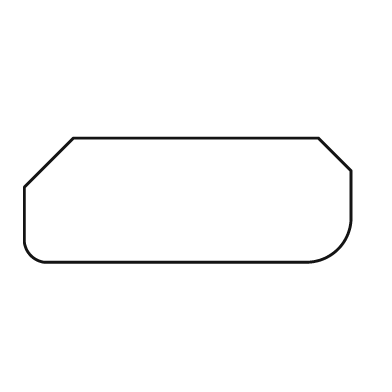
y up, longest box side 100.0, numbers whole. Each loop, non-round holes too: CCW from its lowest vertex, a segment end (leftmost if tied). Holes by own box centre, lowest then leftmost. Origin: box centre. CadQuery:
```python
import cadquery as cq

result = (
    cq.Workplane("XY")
    .moveTo(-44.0, -19.0)
    .lineTo(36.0, -19.0)
    .threePointArc((46.0, -15.0), (50.0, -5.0))
    .lineTo(50.0, 9.0)
    .lineTo(40.0, 19.0)
    .lineTo(-35.0, 19.0)
    .lineTo(-50.0, 4.0)
    .lineTo(-50.0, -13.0)
    .threePointArc((-48.0, -17.0), (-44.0, -19.0))
    .close()
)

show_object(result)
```